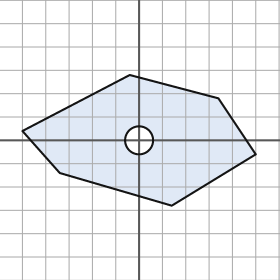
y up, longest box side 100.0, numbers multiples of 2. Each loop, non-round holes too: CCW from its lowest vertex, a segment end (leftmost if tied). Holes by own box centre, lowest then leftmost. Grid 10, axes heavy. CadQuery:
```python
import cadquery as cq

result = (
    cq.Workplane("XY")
    .moveTo(14.0, -28.0)
    .lineTo(50.0, -6.0)
    .lineTo(34.0, 18.0)
    .lineTo(-4.0, 28.0)
    .lineTo(-50.0, 4.0)
    .lineTo(-34.0, -14.0)
    .close()
    .moveTo(0.0, 0.0)
    .circle(6.0)
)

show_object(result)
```